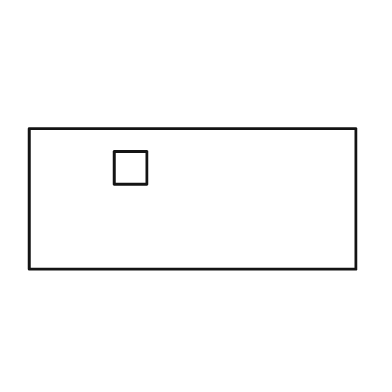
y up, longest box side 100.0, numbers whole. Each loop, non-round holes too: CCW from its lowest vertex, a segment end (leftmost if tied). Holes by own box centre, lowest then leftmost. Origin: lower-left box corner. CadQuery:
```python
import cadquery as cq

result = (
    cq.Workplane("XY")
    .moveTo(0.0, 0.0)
    .lineTo(100.0, 0.0)
    .lineTo(100.0, 43.0)
    .lineTo(0.0, 43.0)
    .close()
    .moveTo(26.0, 26.0)
    .lineTo(36.0, 26.0)
    .lineTo(36.0, 36.0)
    .lineTo(26.0, 36.0)
    .close()
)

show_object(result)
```